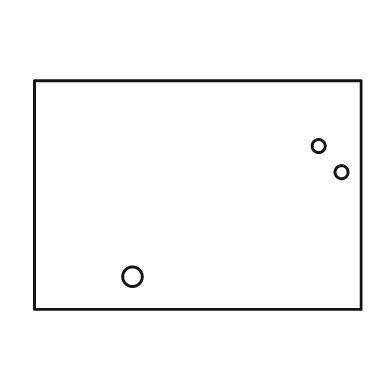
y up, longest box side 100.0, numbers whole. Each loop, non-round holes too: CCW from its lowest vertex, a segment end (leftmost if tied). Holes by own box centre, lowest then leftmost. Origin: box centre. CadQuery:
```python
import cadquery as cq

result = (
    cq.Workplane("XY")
    .moveTo(-50.0, -35.0)
    .lineTo(50.0, -35.0)
    .lineTo(50.0, 35.0)
    .lineTo(-50.0, 35.0)
    .close()
    .moveTo(-20.0, -25.0)
    .circle(3.0)
    .moveTo(44.0, 7.0)
    .circle(2.0)
    .moveTo(37.0, 15.0)
    .circle(2.0)
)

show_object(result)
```